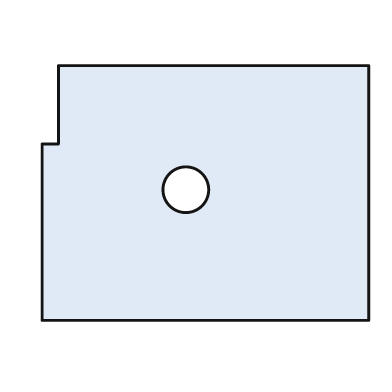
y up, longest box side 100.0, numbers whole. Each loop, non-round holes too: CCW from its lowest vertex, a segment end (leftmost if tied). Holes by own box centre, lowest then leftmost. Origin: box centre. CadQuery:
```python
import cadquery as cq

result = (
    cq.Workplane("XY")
    .moveTo(-50.0, -39.0)
    .lineTo(50.0, -39.0)
    .lineTo(50.0, 39.0)
    .lineTo(-45.0, 39.0)
    .lineTo(-45.0, 15.0)
    .lineTo(-50.0, 15.0)
    .close()
    .moveTo(-6.0, 1.0)
    .circle(7.0)
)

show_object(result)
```